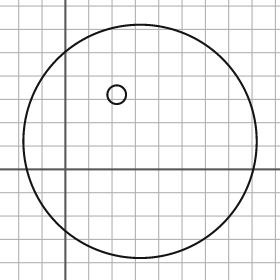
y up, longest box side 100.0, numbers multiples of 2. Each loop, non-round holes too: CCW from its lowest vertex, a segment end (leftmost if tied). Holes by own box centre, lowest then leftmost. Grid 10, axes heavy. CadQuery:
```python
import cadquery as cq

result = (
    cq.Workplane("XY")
    .moveTo(32.0, 12.0)
    .circle(50.0)
    .moveTo(22.0, 32.0)
    .circle(4.0)
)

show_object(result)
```